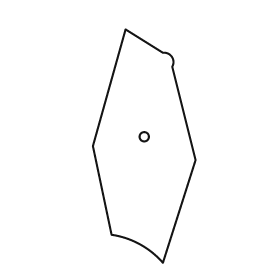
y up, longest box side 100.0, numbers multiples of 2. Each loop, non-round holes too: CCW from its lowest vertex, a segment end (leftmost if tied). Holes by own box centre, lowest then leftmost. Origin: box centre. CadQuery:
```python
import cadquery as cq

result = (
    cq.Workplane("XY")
    .moveTo(8.0, -50.0)
    .lineTo(22.0, -6.0)
    .lineTo(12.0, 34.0)
    .threePointArc((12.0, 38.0), (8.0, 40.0))
    .lineTo(-8.0, 50.0)
    .lineTo(-22.0, 0.0)
    .lineTo(-14.0, -38.0)
    .threePointArc((-2.0, -42.0), (8.0, -50.0))
    .close()
    .moveTo(0.0, 4.0)
    .circle(2.0)
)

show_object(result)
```